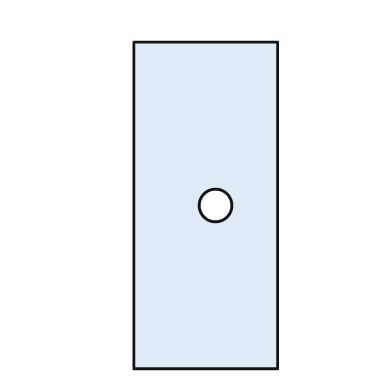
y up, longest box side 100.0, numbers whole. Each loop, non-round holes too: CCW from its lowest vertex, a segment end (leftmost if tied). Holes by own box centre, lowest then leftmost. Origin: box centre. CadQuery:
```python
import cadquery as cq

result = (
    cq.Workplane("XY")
    .moveTo(-22.0, -50.0)
    .lineTo(22.0, -50.0)
    .lineTo(22.0, 50.0)
    .lineTo(-22.0, 50.0)
    .close()
    .moveTo(3.0, 0.0)
    .circle(5.0)
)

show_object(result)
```